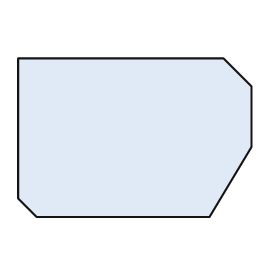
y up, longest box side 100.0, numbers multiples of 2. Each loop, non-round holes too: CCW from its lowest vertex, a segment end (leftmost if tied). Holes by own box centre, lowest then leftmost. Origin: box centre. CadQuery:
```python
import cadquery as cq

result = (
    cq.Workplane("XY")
    .moveTo(-42.0, -34.0)
    .lineTo(32.0, -34.0)
    .lineTo(50.0, -4.0)
    .lineTo(50.0, 22.0)
    .lineTo(38.0, 34.0)
    .lineTo(-50.0, 34.0)
    .lineTo(-50.0, -26.0)
    .close()
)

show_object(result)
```